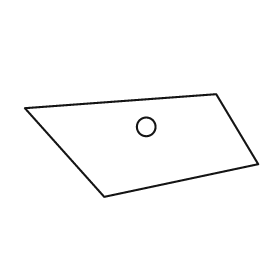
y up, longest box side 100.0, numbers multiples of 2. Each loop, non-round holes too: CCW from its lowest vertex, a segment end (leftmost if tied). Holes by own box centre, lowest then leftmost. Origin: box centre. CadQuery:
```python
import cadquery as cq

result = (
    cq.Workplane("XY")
    .moveTo(-16.0, -22.0)
    .lineTo(50.0, -8.0)
    .lineTo(32.0, 22.0)
    .lineTo(-50.0, 16.0)
    .close()
    .moveTo(2.0, 8.0)
    .circle(4.0)
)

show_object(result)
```